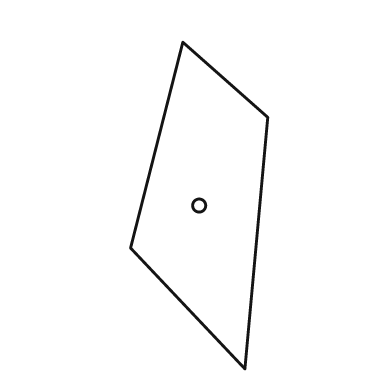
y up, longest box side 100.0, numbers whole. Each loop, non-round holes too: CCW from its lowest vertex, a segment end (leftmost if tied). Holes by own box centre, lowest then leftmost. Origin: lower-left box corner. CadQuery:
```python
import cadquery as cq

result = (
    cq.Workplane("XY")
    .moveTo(35.0, 0.0)
    .lineTo(42.0, 77.0)
    .lineTo(16.0, 100.0)
    .lineTo(0.0, 37.0)
    .close()
    .moveTo(21.0, 50.0)
    .circle(2.0)
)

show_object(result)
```